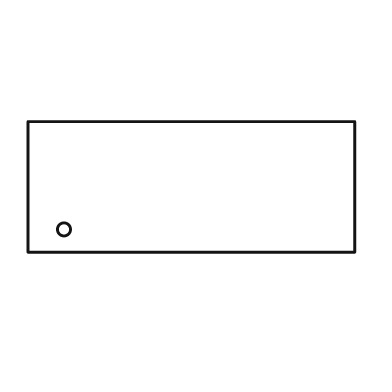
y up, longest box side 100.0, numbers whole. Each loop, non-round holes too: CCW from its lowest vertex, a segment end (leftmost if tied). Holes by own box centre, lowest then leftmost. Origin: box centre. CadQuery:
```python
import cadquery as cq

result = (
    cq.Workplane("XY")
    .moveTo(-50.0, -20.0)
    .lineTo(50.0, -20.0)
    .lineTo(50.0, 20.0)
    .lineTo(-50.0, 20.0)
    .close()
    .moveTo(-39.0, -13.0)
    .circle(2.0)
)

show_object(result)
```